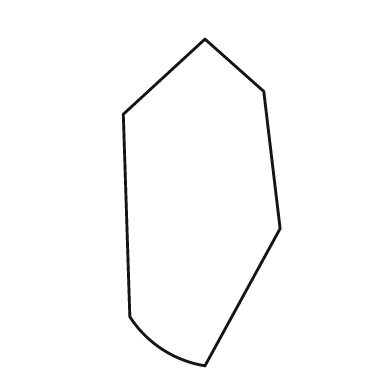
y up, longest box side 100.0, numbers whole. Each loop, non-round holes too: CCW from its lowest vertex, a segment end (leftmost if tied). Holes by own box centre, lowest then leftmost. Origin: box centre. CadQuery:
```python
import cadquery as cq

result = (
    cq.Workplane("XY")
    .moveTo(1.0, -50.0)
    .lineTo(24.0, -8.0)
    .lineTo(19.0, 34.0)
    .lineTo(1.0, 50.0)
    .lineTo(-24.0, 27.0)
    .lineTo(-22.0, -35.0)
    .threePointArc((-12.0, -45.0), (1.0, -50.0))
    .close()
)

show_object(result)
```